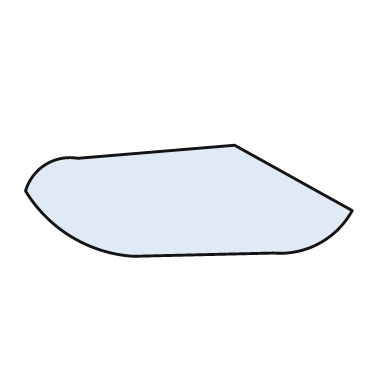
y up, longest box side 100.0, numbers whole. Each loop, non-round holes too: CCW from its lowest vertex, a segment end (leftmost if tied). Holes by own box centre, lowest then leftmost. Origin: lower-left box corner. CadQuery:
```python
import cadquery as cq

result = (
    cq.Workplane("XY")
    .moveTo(33.0, 0.0)
    .lineTo(76.0, 1.0)
    .threePointArc((90.0, 4.0), (100.0, 14.0))
    .lineTo(64.0, 34.0)
    .lineTo(16.0, 30.0)
    .threePointArc((6.0, 28.0), (0.0, 20.0))
    .threePointArc((14.0, 6.0), (33.0, 0.0))
    .close()
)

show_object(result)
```